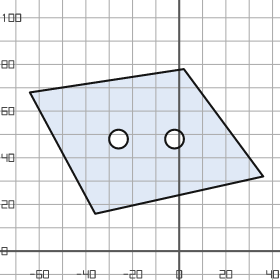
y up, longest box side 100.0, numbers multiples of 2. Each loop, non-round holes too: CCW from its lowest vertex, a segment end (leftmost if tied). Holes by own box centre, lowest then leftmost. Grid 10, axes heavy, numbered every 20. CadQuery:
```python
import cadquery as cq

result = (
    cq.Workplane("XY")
    .moveTo(-36.0, 16.0)
    .lineTo(36.0, 32.0)
    .lineTo(2.0, 78.0)
    .lineTo(-64.0, 68.0)
    .close()
    .moveTo(-26.0, 48.0)
    .circle(4.0)
    .moveTo(-2.0, 48.0)
    .circle(4.0)
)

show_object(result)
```